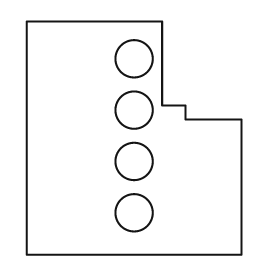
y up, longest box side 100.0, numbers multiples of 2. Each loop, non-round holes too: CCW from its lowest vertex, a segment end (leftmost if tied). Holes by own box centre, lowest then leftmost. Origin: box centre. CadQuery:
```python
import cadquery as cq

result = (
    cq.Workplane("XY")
    .moveTo(-46.0, -50.0)
    .lineTo(46.0, -50.0)
    .lineTo(46.0, 8.0)
    .lineTo(22.0, 8.0)
    .lineTo(22.0, 14.0)
    .lineTo(12.0, 14.0)
    .lineTo(12.0, 50.0)
    .lineTo(-46.0, 50.0)
    .close()
    .moveTo(0.0, -32.0)
    .circle(8.0)
    .moveTo(0.0, -10.0)
    .circle(8.0)
    .moveTo(0.0, 12.0)
    .circle(8.0)
    .moveTo(0.0, 34.0)
    .circle(8.0)
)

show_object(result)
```